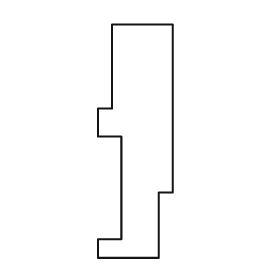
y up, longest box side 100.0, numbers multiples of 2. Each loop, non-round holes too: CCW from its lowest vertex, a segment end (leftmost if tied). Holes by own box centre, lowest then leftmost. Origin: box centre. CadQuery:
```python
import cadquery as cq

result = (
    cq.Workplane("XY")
    .moveTo(-16.0, -50.0)
    .lineTo(10.0, -50.0)
    .lineTo(10.0, -22.0)
    .lineTo(16.0, -22.0)
    .lineTo(16.0, 50.0)
    .lineTo(-10.0, 50.0)
    .lineTo(-10.0, 14.0)
    .lineTo(-16.0, 14.0)
    .lineTo(-16.0, 2.0)
    .lineTo(-6.0, 2.0)
    .lineTo(-6.0, -42.0)
    .lineTo(-16.0, -42.0)
    .close()
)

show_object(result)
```